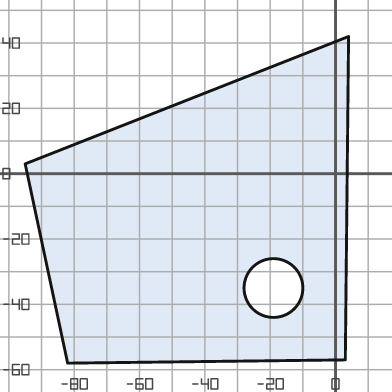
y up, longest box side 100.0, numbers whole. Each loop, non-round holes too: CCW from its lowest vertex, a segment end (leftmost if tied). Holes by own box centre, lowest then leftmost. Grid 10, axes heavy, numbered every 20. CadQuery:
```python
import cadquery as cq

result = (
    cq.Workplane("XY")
    .moveTo(-82.0, -58.0)
    .lineTo(3.0, -57.0)
    .lineTo(4.0, 42.0)
    .lineTo(-95.0, 3.0)
    .close()
    .moveTo(-19.0, -35.0)
    .circle(9.0)
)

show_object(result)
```